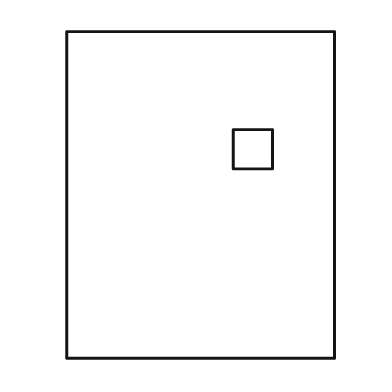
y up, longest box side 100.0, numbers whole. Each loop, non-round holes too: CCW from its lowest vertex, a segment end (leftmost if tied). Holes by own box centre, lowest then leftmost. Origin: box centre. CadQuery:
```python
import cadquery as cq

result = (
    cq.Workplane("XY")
    .moveTo(-41.0, -50.0)
    .lineTo(41.0, -50.0)
    .lineTo(41.0, 50.0)
    .lineTo(-41.0, 50.0)
    .close()
    .moveTo(10.0, 8.0)
    .lineTo(22.0, 8.0)
    .lineTo(22.0, 20.0)
    .lineTo(10.0, 20.0)
    .close()
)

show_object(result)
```